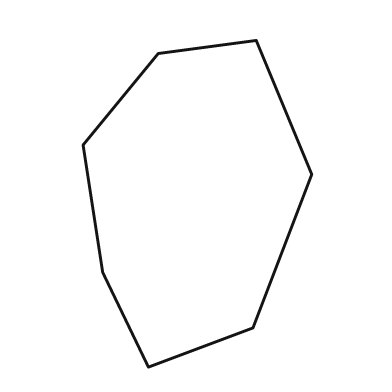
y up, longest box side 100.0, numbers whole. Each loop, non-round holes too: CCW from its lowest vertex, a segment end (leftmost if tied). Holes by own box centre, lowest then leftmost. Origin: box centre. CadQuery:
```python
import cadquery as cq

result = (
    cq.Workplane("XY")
    .moveTo(-15.0, -50.0)
    .lineTo(17.0, -38.0)
    .lineTo(35.0, 9.0)
    .lineTo(18.0, 50.0)
    .lineTo(-12.0, 46.0)
    .lineTo(-35.0, 18.0)
    .lineTo(-29.0, -21.0)
    .close()
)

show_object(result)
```